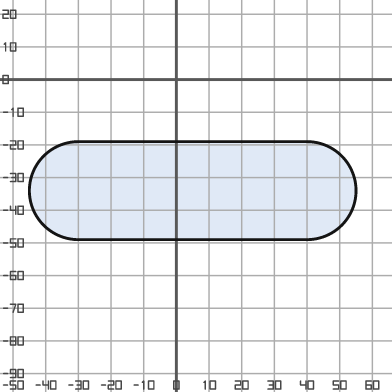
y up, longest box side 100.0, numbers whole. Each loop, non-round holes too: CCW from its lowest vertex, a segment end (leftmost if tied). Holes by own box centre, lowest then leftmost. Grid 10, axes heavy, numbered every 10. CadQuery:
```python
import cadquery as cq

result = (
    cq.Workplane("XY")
    .moveTo(-30.0, -49.0)
    .lineTo(40.0, -49.0)
    .threePointArc((55.0, -34.0), (40.0, -19.0))
    .lineTo(-30.0, -19.0)
    .threePointArc((-45.0, -34.0), (-30.0, -49.0))
    .close()
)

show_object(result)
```